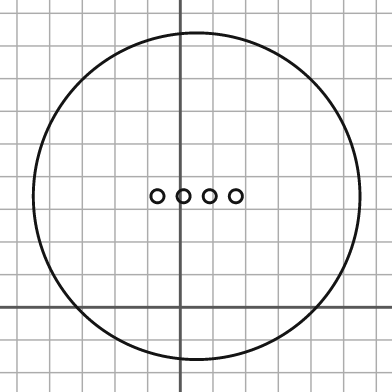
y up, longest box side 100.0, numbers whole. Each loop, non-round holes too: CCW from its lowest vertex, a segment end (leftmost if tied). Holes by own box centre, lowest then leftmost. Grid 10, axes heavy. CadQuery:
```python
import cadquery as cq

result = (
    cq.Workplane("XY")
    .moveTo(5.0, 34.0)
    .circle(50.0)
    .moveTo(-7.0, 34.0)
    .circle(2.0)
    .moveTo(1.0, 34.0)
    .circle(2.0)
    .moveTo(9.0, 34.0)
    .circle(2.0)
    .moveTo(17.0, 34.0)
    .circle(2.0)
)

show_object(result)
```